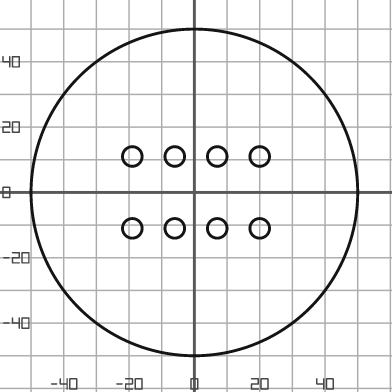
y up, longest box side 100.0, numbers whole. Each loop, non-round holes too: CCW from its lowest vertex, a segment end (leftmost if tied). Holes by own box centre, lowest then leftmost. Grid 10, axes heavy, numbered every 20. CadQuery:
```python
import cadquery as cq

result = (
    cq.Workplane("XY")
    .moveTo(0.0, 0.0)
    .circle(50.0)
    .moveTo(-19.0, -11.0)
    .circle(3.0)
    .moveTo(-6.0, -11.0)
    .circle(3.0)
    .moveTo(7.0, -11.0)
    .circle(3.0)
    .moveTo(20.0, -11.0)
    .circle(3.0)
    .moveTo(-19.0, 11.0)
    .circle(3.0)
    .moveTo(-6.0, 11.0)
    .circle(3.0)
    .moveTo(7.0, 11.0)
    .circle(3.0)
    .moveTo(20.0, 11.0)
    .circle(3.0)
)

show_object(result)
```